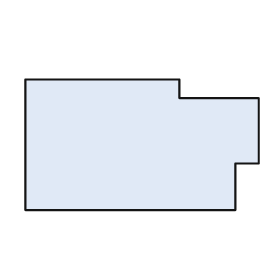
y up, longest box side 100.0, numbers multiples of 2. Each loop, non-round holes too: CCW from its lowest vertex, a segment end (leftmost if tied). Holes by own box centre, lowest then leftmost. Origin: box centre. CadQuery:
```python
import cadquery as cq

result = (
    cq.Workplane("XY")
    .moveTo(-50.0, -28.0)
    .lineTo(40.0, -28.0)
    .lineTo(40.0, -8.0)
    .lineTo(50.0, -8.0)
    .lineTo(50.0, 20.0)
    .lineTo(16.0, 20.0)
    .lineTo(16.0, 28.0)
    .lineTo(-50.0, 28.0)
    .close()
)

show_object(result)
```